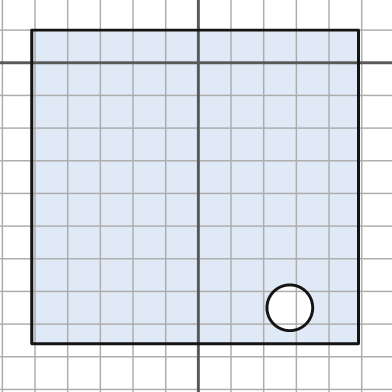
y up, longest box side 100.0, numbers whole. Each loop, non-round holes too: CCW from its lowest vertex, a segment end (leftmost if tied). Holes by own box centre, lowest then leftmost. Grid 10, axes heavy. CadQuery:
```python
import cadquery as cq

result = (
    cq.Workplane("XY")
    .moveTo(-51.0, -86.0)
    .lineTo(49.0, -86.0)
    .lineTo(49.0, 10.0)
    .lineTo(-51.0, 10.0)
    .close()
    .moveTo(28.0, -75.0)
    .circle(7.0)
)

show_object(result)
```